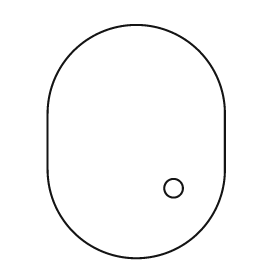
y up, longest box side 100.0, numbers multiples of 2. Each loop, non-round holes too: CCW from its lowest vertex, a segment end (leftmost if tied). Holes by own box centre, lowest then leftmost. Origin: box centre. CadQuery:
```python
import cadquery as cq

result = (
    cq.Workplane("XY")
    .moveTo(-38.0, -12.0)
    .threePointArc((0.0, -50.0), (38.0, -12.0))
    .lineTo(38.0, 12.0)
    .threePointArc((0.0, 50.0), (-38.0, 12.0))
    .close()
    .moveTo(16.0, -20.0)
    .circle(4.0)
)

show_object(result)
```